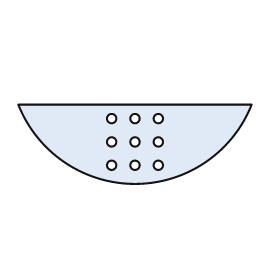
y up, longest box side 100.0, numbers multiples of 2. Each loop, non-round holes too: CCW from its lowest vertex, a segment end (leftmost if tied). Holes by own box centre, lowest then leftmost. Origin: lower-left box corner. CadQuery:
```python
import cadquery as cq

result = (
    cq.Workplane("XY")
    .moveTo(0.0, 34.0)
    .threePointArc((50.0, 0.0), (100.0, 34.0))
    .close()
    .moveTo(40.0, 8.0)
    .circle(2.0)
    .moveTo(50.0, 8.0)
    .circle(2.0)
    .moveTo(60.0, 8.0)
    .circle(2.0)
    .moveTo(40.0, 18.0)
    .circle(2.0)
    .moveTo(50.0, 18.0)
    .circle(2.0)
    .moveTo(60.0, 18.0)
    .circle(2.0)
    .moveTo(40.0, 28.0)
    .circle(2.0)
    .moveTo(50.0, 28.0)
    .circle(2.0)
    .moveTo(60.0, 28.0)
    .circle(2.0)
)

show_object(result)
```